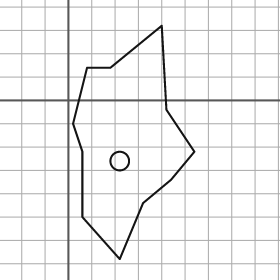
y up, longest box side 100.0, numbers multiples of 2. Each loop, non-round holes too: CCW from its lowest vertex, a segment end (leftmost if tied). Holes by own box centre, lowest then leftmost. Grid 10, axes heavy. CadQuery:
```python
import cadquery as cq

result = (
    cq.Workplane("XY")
    .moveTo(22.0, -68.0)
    .lineTo(32.0, -44.0)
    .lineTo(44.0, -34.0)
    .lineTo(54.0, -22.0)
    .lineTo(42.0, -4.0)
    .lineTo(40.0, 32.0)
    .lineTo(18.0, 14.0)
    .lineTo(8.0, 14.0)
    .lineTo(2.0, -10.0)
    .lineTo(6.0, -22.0)
    .lineTo(6.0, -50.0)
    .close()
    .moveTo(22.0, -26.0)
    .circle(4.0)
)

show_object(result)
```